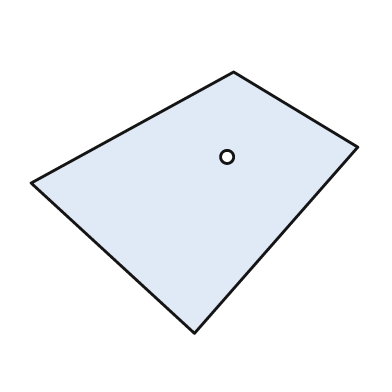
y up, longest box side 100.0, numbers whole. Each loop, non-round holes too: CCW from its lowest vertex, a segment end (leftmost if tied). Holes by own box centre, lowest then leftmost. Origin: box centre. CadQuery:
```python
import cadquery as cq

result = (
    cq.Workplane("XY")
    .moveTo(0.0, -40.0)
    .lineTo(50.0, 17.0)
    .lineTo(12.0, 40.0)
    .lineTo(-50.0, 6.0)
    .close()
    .moveTo(10.0, 14.0)
    .circle(2.0)
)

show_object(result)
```